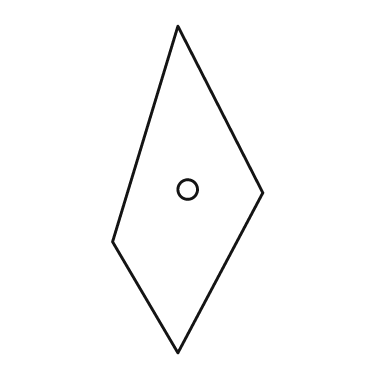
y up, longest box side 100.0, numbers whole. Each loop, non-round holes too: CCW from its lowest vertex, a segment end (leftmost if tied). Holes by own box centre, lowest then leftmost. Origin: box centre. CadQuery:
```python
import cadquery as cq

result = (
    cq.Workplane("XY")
    .moveTo(-3.0, -50.0)
    .lineTo(23.0, -1.0)
    .lineTo(-3.0, 50.0)
    .lineTo(-23.0, -16.0)
    .close()
    .moveTo(0.0, 0.0)
    .circle(3.0)
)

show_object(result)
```